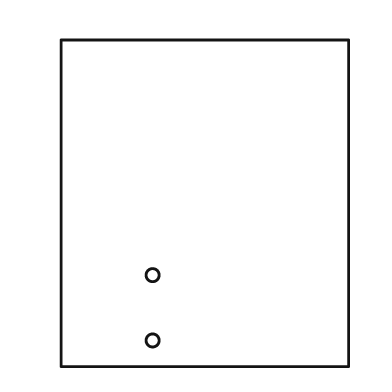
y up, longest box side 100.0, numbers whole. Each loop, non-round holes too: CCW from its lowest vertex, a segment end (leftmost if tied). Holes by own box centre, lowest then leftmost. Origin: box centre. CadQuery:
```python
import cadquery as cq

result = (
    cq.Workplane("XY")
    .moveTo(-44.0, -50.0)
    .lineTo(44.0, -50.0)
    .lineTo(44.0, 50.0)
    .lineTo(-44.0, 50.0)
    .close()
    .moveTo(-16.0, -42.0)
    .circle(2.0)
    .moveTo(-16.0, -22.0)
    .circle(2.0)
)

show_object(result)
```